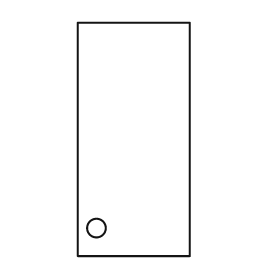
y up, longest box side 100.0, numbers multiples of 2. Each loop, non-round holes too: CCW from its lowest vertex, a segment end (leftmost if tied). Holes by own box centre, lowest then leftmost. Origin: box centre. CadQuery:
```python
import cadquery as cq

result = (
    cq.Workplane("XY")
    .moveTo(-24.0, -50.0)
    .lineTo(24.0, -50.0)
    .lineTo(24.0, 50.0)
    .lineTo(-24.0, 50.0)
    .close()
    .moveTo(-16.0, -38.0)
    .circle(4.0)
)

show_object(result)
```